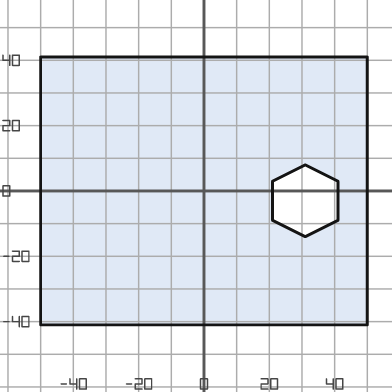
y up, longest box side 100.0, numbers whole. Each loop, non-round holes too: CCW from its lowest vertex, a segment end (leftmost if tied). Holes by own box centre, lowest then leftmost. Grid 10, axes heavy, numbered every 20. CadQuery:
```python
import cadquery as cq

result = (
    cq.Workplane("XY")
    .moveTo(-50.0, -41.0)
    .lineTo(50.0, -41.0)
    .lineTo(50.0, 41.0)
    .lineTo(-50.0, 41.0)
    .close()
    .moveTo(31.0, -14.0)
    .lineTo(41.0, -9.0)
    .lineTo(41.0, 3.0)
    .lineTo(31.0, 8.0)
    .lineTo(21.0, 3.0)
    .lineTo(21.0, -9.0)
    .close()
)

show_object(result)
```